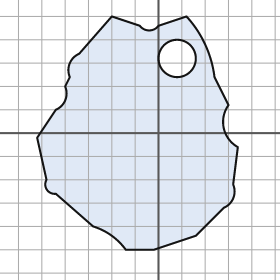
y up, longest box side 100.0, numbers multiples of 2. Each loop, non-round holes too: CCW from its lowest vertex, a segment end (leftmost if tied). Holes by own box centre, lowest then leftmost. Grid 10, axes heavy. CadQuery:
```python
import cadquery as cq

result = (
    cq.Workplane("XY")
    .moveTo(-14.0, -50.0)
    .lineTo(-2.0, -50.0)
    .lineTo(16.0, -44.0)
    .lineTo(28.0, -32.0)
    .threePointArc((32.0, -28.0), (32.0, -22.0))
    .lineTo(34.0, -6.0)
    .threePointArc((28.0, 2.0), (30.0, 12.0))
    .lineTo(24.0, 24.0)
    .threePointArc((20.0, 38.0), (12.0, 50.0))
    .lineTo(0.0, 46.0)
    .threePointArc((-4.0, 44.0), (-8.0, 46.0))
    .lineTo(-20.0, 50.0)
    .lineTo(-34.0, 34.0)
    .threePointArc((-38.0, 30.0), (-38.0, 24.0))
    .lineTo(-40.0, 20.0)
    .threePointArc((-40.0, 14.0), (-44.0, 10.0))
    .lineTo(-52.0, -2.0)
    .lineTo(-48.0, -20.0)
    .threePointArc((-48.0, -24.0), (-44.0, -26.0))
    .lineTo(-28.0, -40.0)
    .threePointArc((-20.0, -44.0), (-14.0, -50.0))
    .close()
    .moveTo(8.0, 32.0)
    .circle(8.0)
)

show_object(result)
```